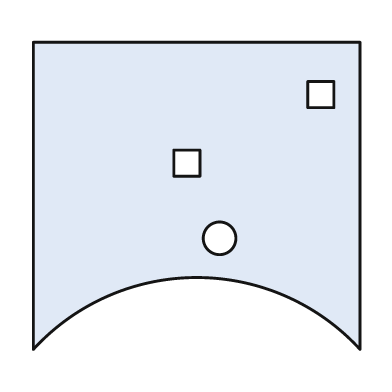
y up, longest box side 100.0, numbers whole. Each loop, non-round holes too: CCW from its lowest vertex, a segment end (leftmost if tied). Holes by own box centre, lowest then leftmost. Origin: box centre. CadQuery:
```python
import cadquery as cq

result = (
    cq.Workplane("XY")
    .moveTo(-50.0, -47.0)
    .threePointArc((0.0, -25.0), (50.0, -47.0))
    .lineTo(50.0, 47.0)
    .lineTo(-50.0, 47.0)
    .close()
    .moveTo(7.0, -13.0)
    .circle(5.0)
    .moveTo(-7.0, 6.0)
    .lineTo(1.0, 6.0)
    .lineTo(1.0, 14.0)
    .lineTo(-7.0, 14.0)
    .close()
    .moveTo(34.0, 27.0)
    .lineTo(42.0, 27.0)
    .lineTo(42.0, 35.0)
    .lineTo(34.0, 35.0)
    .close()
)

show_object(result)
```